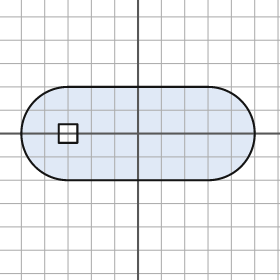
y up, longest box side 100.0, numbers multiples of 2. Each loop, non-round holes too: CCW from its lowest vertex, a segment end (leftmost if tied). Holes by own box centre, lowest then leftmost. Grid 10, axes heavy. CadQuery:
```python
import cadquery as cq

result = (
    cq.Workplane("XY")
    .moveTo(-30.0, -20.0)
    .lineTo(30.0, -20.0)
    .threePointArc((50.0, 0.0), (30.0, 20.0))
    .lineTo(-30.0, 20.0)
    .threePointArc((-50.0, 0.0), (-30.0, -20.0))
    .close()
    .moveTo(-34.0, -4.0)
    .lineTo(-26.0, -4.0)
    .lineTo(-26.0, 4.0)
    .lineTo(-34.0, 4.0)
    .close()
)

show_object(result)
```